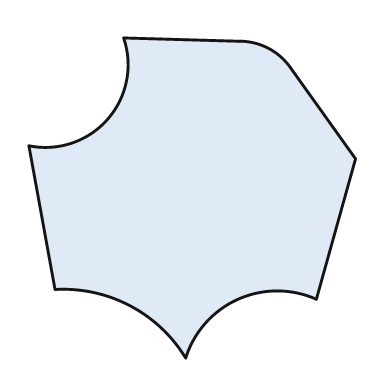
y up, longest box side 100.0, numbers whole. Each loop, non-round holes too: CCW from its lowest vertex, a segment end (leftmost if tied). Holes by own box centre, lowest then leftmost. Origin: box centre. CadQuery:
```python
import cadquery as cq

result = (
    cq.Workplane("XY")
    .moveTo(-2.0, -49.0)
    .threePointArc((14.0, -31.0), (38.0, -31.0))
    .lineTo(50.0, 12.0)
    .lineTo(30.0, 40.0)
    .threePointArc((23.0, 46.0), (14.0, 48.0))
    .lineTo(-21.0, 49.0)
    .threePointArc((-26.0, 24.0), (-50.0, 16.0))
    .lineTo(-42.0, -28.0)
    .threePointArc((-19.0, -33.0), (-2.0, -49.0))
    .close()
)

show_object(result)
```